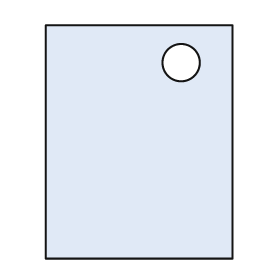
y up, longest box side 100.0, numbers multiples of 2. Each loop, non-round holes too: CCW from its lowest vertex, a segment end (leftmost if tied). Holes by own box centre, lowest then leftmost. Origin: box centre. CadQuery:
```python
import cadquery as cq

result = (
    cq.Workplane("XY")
    .moveTo(-40.0, -50.0)
    .lineTo(40.0, -50.0)
    .lineTo(40.0, 50.0)
    .lineTo(-40.0, 50.0)
    .close()
    .moveTo(18.0, 34.0)
    .circle(8.0)
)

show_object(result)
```